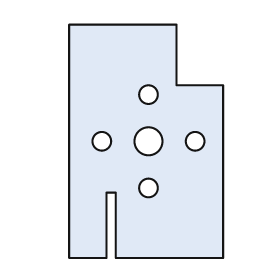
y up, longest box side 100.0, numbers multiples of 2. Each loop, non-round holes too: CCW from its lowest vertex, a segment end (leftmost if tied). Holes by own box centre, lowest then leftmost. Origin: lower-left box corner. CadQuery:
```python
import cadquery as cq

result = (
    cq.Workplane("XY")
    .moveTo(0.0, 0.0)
    .lineTo(16.0, 0.0)
    .lineTo(16.0, 28.0)
    .lineTo(20.0, 28.0)
    .lineTo(20.0, 0.0)
    .lineTo(66.0, 0.0)
    .lineTo(66.0, 74.0)
    .lineTo(46.0, 74.0)
    .lineTo(46.0, 100.0)
    .lineTo(0.0, 100.0)
    .close()
    .moveTo(34.0, 30.0)
    .circle(4.0)
    .moveTo(14.0, 50.0)
    .circle(4.0)
    .moveTo(34.0, 50.0)
    .circle(6.0)
    .moveTo(54.0, 50.0)
    .circle(4.0)
    .moveTo(34.0, 70.0)
    .circle(4.0)
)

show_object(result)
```